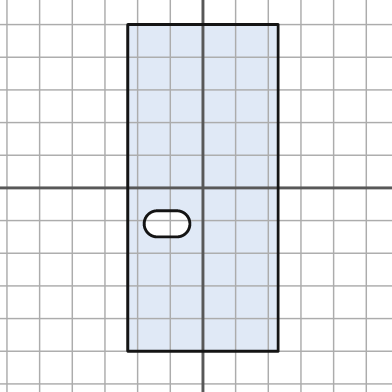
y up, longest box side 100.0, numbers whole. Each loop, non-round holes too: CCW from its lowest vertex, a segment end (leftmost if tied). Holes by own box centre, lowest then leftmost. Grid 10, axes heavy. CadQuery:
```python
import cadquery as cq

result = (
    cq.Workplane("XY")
    .moveTo(-23.0, -50.0)
    .lineTo(23.0, -50.0)
    .lineTo(23.0, 50.0)
    .lineTo(-23.0, 50.0)
    .close()
    .moveTo(-14.0, -15.0)
    .lineTo(-8.0, -15.0)
    .threePointArc((-4.0, -11.0), (-8.0, -7.0))
    .lineTo(-14.0, -7.0)
    .threePointArc((-18.0, -11.0), (-14.0, -15.0))
    .close()
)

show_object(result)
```